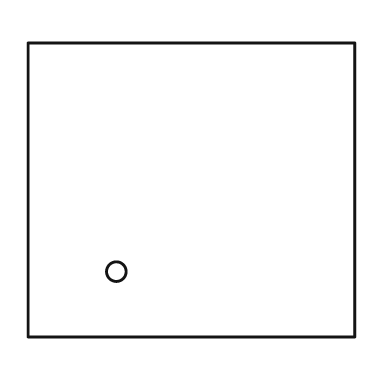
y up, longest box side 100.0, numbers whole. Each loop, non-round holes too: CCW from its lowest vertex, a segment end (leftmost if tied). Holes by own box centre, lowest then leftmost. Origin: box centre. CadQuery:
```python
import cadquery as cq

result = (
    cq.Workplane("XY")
    .moveTo(-50.0, -45.0)
    .lineTo(50.0, -45.0)
    .lineTo(50.0, 45.0)
    .lineTo(-50.0, 45.0)
    .close()
    .moveTo(-23.0, -25.0)
    .circle(3.0)
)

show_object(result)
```